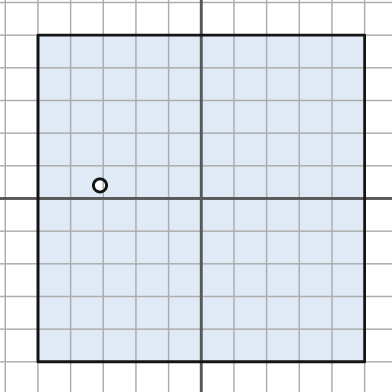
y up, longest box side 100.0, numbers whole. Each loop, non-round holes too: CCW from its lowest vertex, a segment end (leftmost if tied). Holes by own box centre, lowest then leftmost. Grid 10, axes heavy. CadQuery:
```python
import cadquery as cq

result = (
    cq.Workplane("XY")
    .moveTo(-50.0, -50.0)
    .lineTo(50.0, -50.0)
    .lineTo(50.0, 50.0)
    .lineTo(-50.0, 50.0)
    .close()
    .moveTo(-31.0, 4.0)
    .circle(2.0)
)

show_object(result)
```